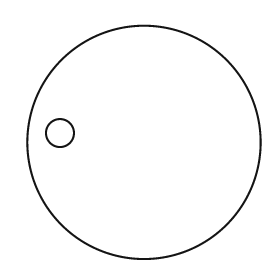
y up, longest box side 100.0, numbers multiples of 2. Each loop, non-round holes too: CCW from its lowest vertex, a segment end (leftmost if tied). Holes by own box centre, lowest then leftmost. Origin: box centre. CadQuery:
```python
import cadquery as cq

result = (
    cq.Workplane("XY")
    .moveTo(0.0, 0.0)
    .circle(50.0)
    .moveTo(-36.0, 4.0)
    .circle(6.0)
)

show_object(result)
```